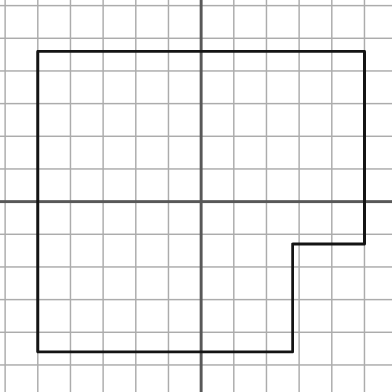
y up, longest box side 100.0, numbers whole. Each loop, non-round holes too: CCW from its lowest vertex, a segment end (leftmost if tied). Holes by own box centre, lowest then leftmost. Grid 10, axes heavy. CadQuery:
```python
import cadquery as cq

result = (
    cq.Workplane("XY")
    .moveTo(-50.0, -46.0)
    .lineTo(28.0, -46.0)
    .lineTo(28.0, -13.0)
    .lineTo(50.0, -13.0)
    .lineTo(50.0, 46.0)
    .lineTo(-50.0, 46.0)
    .close()
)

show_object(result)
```